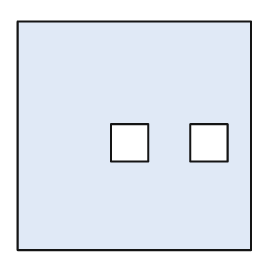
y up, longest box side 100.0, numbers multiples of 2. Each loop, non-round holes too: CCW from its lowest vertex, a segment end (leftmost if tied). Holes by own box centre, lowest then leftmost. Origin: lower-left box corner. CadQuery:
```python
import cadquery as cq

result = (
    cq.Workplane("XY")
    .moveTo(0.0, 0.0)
    .lineTo(100.0, 0.0)
    .lineTo(100.0, 98.0)
    .lineTo(0.0, 98.0)
    .close()
    .moveTo(40.0, 38.0)
    .lineTo(56.0, 38.0)
    .lineTo(56.0, 54.0)
    .lineTo(40.0, 54.0)
    .close()
    .moveTo(74.0, 38.0)
    .lineTo(90.0, 38.0)
    .lineTo(90.0, 54.0)
    .lineTo(74.0, 54.0)
    .close()
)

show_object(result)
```